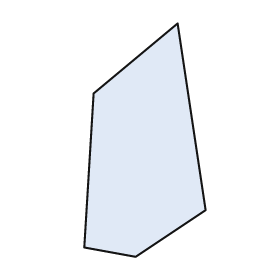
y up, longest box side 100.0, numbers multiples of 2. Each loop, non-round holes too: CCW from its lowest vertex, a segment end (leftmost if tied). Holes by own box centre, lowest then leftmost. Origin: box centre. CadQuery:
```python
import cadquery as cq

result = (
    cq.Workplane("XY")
    .moveTo(-4.0, -50.0)
    .lineTo(26.0, -30.0)
    .lineTo(14.0, 50.0)
    .lineTo(-22.0, 20.0)
    .lineTo(-26.0, -46.0)
    .close()
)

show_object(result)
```